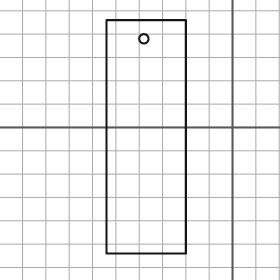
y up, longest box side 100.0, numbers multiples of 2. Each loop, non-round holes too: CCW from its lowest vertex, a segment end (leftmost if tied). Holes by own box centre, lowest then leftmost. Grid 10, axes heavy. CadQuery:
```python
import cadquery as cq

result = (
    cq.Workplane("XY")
    .moveTo(-54.0, -54.0)
    .lineTo(-20.0, -54.0)
    .lineTo(-20.0, 46.0)
    .lineTo(-54.0, 46.0)
    .close()
    .moveTo(-38.0, 38.0)
    .circle(2.0)
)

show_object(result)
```